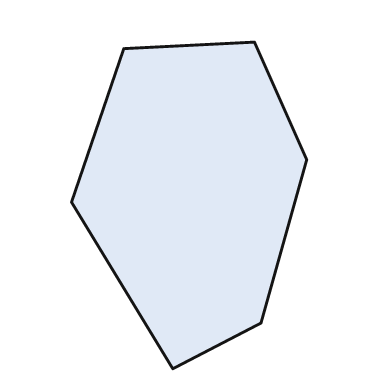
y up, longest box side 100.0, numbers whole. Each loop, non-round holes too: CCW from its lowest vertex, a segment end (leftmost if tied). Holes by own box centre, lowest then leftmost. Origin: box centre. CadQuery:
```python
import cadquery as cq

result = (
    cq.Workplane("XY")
    .moveTo(-5.0, -50.0)
    .lineTo(22.0, -36.0)
    .lineTo(36.0, 14.0)
    .lineTo(20.0, 50.0)
    .lineTo(-20.0, 48.0)
    .lineTo(-36.0, 1.0)
    .close()
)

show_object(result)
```